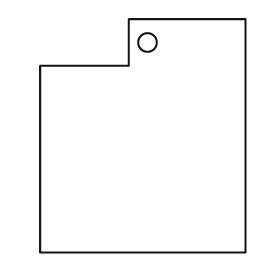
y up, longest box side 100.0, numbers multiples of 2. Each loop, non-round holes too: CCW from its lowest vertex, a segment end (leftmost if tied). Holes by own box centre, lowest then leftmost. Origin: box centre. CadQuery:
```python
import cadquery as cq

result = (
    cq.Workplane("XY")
    .moveTo(-44.0, -50.0)
    .lineTo(44.0, -50.0)
    .lineTo(44.0, 50.0)
    .lineTo(-6.0, 50.0)
    .lineTo(-6.0, 30.0)
    .lineTo(-44.0, 30.0)
    .close()
    .moveTo(2.0, 40.0)
    .circle(4.0)
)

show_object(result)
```